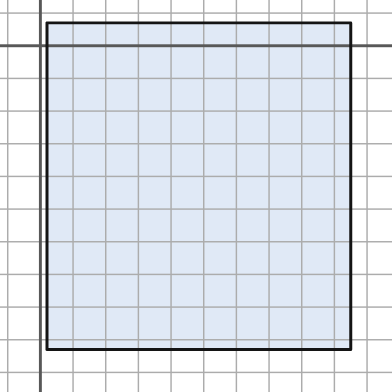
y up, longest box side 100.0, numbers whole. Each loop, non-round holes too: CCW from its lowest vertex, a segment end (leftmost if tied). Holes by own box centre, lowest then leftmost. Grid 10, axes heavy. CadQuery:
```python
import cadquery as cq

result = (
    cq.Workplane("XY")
    .moveTo(2.0, -93.0)
    .lineTo(95.0, -93.0)
    .lineTo(95.0, 7.0)
    .lineTo(2.0, 7.0)
    .close()
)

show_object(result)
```